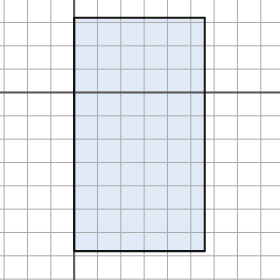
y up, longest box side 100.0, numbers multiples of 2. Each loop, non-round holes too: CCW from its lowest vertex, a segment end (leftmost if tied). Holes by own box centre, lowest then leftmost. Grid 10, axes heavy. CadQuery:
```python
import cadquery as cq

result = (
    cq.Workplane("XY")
    .moveTo(0.0, -68.0)
    .lineTo(56.0, -68.0)
    .lineTo(56.0, 32.0)
    .lineTo(0.0, 32.0)
    .close()
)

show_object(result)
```